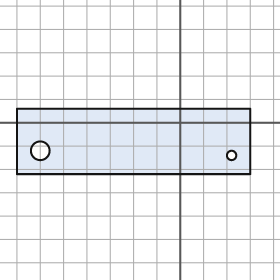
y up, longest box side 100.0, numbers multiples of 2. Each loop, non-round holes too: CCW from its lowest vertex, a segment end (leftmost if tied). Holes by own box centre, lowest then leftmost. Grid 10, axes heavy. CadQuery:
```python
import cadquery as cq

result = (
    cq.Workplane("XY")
    .moveTo(-70.0, -22.0)
    .lineTo(30.0, -22.0)
    .lineTo(30.0, 6.0)
    .lineTo(-70.0, 6.0)
    .close()
    .moveTo(22.0, -14.0)
    .circle(2.0)
    .moveTo(-60.0, -12.0)
    .circle(4.0)
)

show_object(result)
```